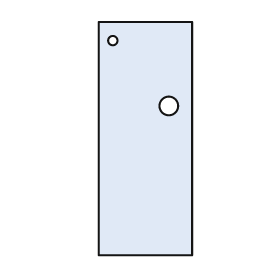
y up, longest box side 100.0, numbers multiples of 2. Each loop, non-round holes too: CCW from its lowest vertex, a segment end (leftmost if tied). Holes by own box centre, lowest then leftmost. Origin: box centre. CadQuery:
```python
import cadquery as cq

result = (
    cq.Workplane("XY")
    .moveTo(-20.0, -50.0)
    .lineTo(20.0, -50.0)
    .lineTo(20.0, 50.0)
    .lineTo(-20.0, 50.0)
    .close()
    .moveTo(10.0, 14.0)
    .circle(4.0)
    .moveTo(-14.0, 42.0)
    .circle(2.0)
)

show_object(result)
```